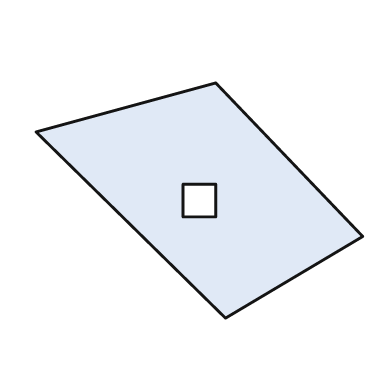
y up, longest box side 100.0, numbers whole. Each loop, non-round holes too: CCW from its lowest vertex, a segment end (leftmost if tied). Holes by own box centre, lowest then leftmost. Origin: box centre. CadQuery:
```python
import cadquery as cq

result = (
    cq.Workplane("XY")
    .moveTo(8.0, -36.0)
    .lineTo(50.0, -11.0)
    .lineTo(5.0, 36.0)
    .lineTo(-50.0, 21.0)
    .close()
    .moveTo(-5.0, -5.0)
    .lineTo(5.0, -5.0)
    .lineTo(5.0, 5.0)
    .lineTo(-5.0, 5.0)
    .close()
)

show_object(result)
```